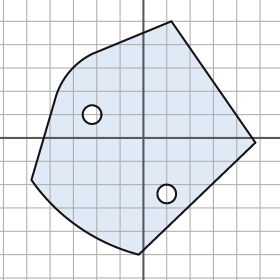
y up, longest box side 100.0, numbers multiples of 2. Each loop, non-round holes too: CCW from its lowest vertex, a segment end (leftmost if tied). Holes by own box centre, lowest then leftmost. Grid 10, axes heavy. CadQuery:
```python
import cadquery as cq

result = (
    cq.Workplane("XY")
    .moveTo(-2.0, -50.0)
    .lineTo(48.0, -2.0)
    .lineTo(12.0, 50.0)
    .lineTo(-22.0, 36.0)
    .threePointArc((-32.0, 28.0), (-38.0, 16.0))
    .lineTo(-48.0, -18.0)
    .threePointArc((-28.0, -38.0), (-2.0, -50.0))
    .close()
    .moveTo(10.0, -24.0)
    .circle(4.0)
    .moveTo(-22.0, 10.0)
    .circle(4.0)
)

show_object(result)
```